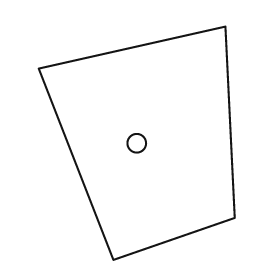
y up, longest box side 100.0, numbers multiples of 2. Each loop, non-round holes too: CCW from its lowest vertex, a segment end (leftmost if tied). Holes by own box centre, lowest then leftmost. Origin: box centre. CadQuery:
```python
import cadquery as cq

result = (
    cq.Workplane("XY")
    .moveTo(-10.0, -50.0)
    .lineTo(42.0, -32.0)
    .lineTo(38.0, 50.0)
    .lineTo(-42.0, 32.0)
    .close()
    .moveTo(0.0, 0.0)
    .circle(4.0)
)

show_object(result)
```